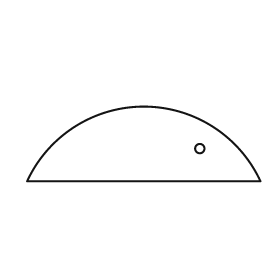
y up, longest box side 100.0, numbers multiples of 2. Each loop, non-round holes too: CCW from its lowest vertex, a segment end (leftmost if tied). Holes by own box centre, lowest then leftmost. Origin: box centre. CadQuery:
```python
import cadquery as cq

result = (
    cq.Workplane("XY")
    .moveTo(-50.0, -16.0)
    .lineTo(50.0, -16.0)
    .threePointArc((0.0, 16.0), (-50.0, -16.0))
    .close()
    .moveTo(24.0, -2.0)
    .circle(2.0)
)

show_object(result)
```